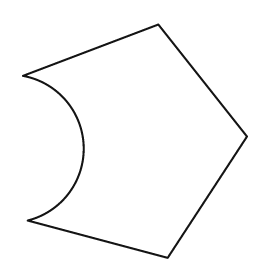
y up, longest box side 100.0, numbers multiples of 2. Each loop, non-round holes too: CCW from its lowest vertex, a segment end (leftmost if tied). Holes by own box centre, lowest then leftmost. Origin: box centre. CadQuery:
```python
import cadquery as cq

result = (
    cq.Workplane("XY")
    .moveTo(14.0, -50.0)
    .lineTo(48.0, 2.0)
    .lineTo(10.0, 50.0)
    .lineTo(-48.0, 28.0)
    .threePointArc((-22.0, -2.0), (-46.0, -34.0))
    .close()
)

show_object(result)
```